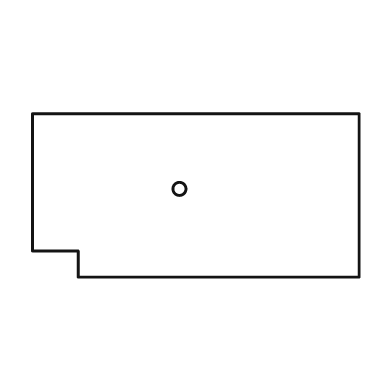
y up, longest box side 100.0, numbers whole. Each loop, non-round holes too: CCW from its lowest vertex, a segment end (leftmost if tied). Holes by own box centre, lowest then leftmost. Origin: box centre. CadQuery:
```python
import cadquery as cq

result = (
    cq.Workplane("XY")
    .moveTo(-36.0, -25.0)
    .lineTo(50.0, -25.0)
    .lineTo(50.0, 25.0)
    .lineTo(-50.0, 25.0)
    .lineTo(-50.0, -17.0)
    .lineTo(-36.0, -17.0)
    .close()
    .moveTo(-5.0, 2.0)
    .circle(2.0)
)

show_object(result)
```